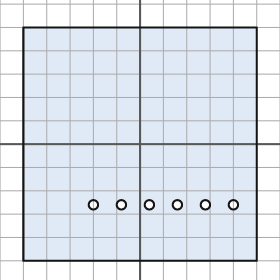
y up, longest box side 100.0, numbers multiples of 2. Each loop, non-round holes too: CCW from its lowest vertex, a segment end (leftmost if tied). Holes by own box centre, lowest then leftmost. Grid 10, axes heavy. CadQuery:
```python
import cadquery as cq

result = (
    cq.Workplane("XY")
    .moveTo(-50.0, -50.0)
    .lineTo(50.0, -50.0)
    .lineTo(50.0, 50.0)
    .lineTo(-50.0, 50.0)
    .close()
    .moveTo(-20.0, -26.0)
    .circle(2.0)
    .moveTo(-8.0, -26.0)
    .circle(2.0)
    .moveTo(4.0, -26.0)
    .circle(2.0)
    .moveTo(16.0, -26.0)
    .circle(2.0)
    .moveTo(28.0, -26.0)
    .circle(2.0)
    .moveTo(40.0, -26.0)
    .circle(2.0)
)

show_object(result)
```